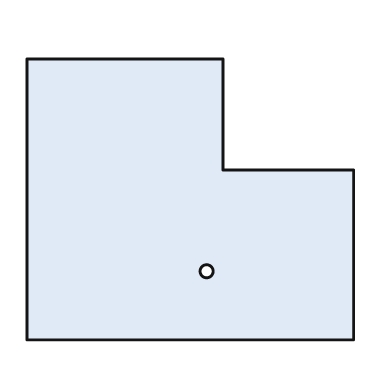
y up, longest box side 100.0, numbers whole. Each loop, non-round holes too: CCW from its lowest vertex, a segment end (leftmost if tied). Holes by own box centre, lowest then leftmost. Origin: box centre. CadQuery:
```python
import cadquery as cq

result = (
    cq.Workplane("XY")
    .moveTo(-50.0, -43.0)
    .lineTo(50.0, -43.0)
    .lineTo(50.0, 9.0)
    .lineTo(10.0, 9.0)
    .lineTo(10.0, 43.0)
    .lineTo(-50.0, 43.0)
    .close()
    .moveTo(5.0, -22.0)
    .circle(2.0)
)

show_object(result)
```